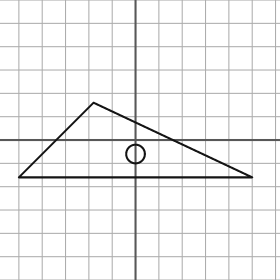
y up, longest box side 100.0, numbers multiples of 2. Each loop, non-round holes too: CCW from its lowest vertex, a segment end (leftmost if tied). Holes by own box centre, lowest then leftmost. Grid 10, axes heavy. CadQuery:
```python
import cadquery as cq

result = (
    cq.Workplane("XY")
    .moveTo(-50.0, -16.0)
    .lineTo(50.0, -16.0)
    .lineTo(-18.0, 16.0)
    .close()
    .moveTo(0.0, -6.0)
    .circle(4.0)
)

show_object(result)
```